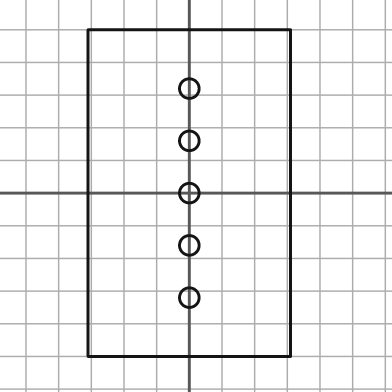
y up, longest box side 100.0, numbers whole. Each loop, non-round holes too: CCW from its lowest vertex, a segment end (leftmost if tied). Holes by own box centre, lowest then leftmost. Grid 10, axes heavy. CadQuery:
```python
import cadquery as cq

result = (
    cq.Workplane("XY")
    .moveTo(-31.0, -50.0)
    .lineTo(31.0, -50.0)
    .lineTo(31.0, 50.0)
    .lineTo(-31.0, 50.0)
    .close()
    .moveTo(0.0, -32.0)
    .circle(3.0)
    .moveTo(0.0, -16.0)
    .circle(3.0)
    .moveTo(0.0, 0.0)
    .circle(3.0)
    .moveTo(0.0, 16.0)
    .circle(3.0)
    .moveTo(0.0, 32.0)
    .circle(3.0)
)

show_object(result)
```